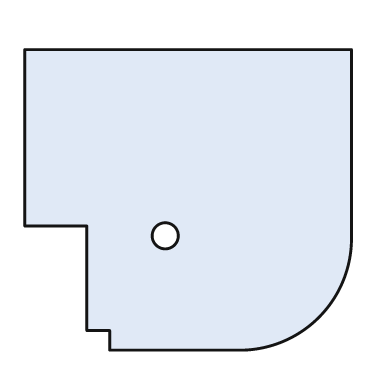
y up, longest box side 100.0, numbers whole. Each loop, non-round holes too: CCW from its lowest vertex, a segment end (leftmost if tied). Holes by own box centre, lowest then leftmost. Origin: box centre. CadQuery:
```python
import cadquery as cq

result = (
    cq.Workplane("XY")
    .moveTo(-24.0, -46.0)
    .lineTo(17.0, -46.0)
    .threePointArc((40.0, -36.0), (50.0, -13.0))
    .lineTo(50.0, 46.0)
    .lineTo(-50.0, 46.0)
    .lineTo(-50.0, -8.0)
    .lineTo(-31.0, -8.0)
    .lineTo(-31.0, -40.0)
    .lineTo(-24.0, -40.0)
    .close()
    .moveTo(-7.0, -11.0)
    .circle(4.0)
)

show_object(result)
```